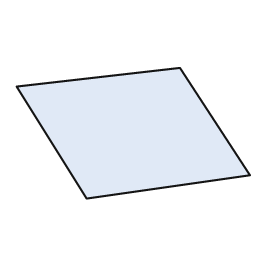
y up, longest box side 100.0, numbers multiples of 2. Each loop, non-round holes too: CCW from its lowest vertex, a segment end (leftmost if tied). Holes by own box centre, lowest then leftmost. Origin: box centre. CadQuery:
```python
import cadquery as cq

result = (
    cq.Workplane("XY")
    .moveTo(-20.0, -28.0)
    .lineTo(50.0, -18.0)
    .lineTo(20.0, 28.0)
    .lineTo(-50.0, 20.0)
    .close()
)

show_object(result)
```